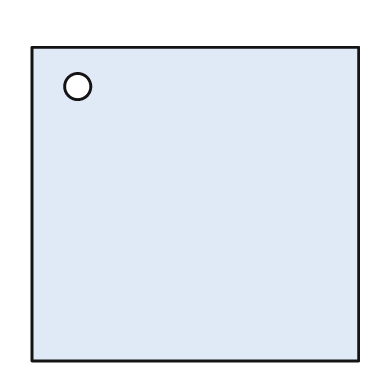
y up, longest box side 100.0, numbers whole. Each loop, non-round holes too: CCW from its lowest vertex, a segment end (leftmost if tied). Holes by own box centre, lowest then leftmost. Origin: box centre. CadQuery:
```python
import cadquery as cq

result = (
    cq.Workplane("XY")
    .moveTo(-50.0, -48.0)
    .lineTo(50.0, -48.0)
    .lineTo(50.0, 48.0)
    .lineTo(-50.0, 48.0)
    .close()
    .moveTo(-36.0, 36.0)
    .circle(4.0)
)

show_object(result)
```